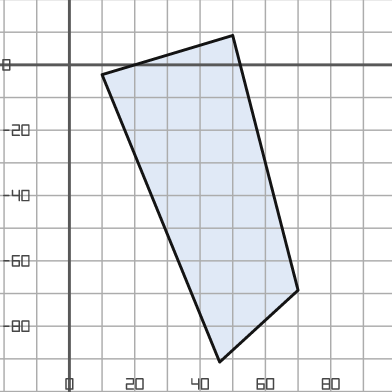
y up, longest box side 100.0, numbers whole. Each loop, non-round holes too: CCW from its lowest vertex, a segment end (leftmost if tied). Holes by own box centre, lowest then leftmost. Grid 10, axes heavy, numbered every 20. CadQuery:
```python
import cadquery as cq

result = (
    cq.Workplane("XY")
    .moveTo(46.0, -91.0)
    .lineTo(70.0, -69.0)
    .lineTo(50.0, 9.0)
    .lineTo(10.0, -3.0)
    .close()
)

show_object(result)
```